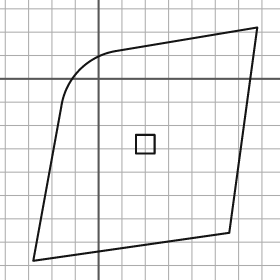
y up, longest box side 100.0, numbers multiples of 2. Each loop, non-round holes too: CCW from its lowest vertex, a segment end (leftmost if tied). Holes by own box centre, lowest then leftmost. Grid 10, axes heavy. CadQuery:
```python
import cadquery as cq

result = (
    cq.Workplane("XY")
    .moveTo(-28.0, -78.0)
    .lineTo(56.0, -66.0)
    .lineTo(68.0, 22.0)
    .lineTo(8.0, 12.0)
    .threePointArc((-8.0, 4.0), (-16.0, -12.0))
    .close()
    .moveTo(16.0, -32.0)
    .lineTo(24.0, -32.0)
    .lineTo(24.0, -24.0)
    .lineTo(16.0, -24.0)
    .close()
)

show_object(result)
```